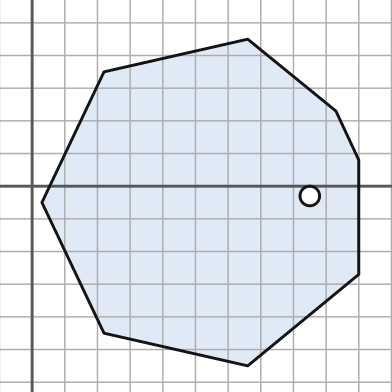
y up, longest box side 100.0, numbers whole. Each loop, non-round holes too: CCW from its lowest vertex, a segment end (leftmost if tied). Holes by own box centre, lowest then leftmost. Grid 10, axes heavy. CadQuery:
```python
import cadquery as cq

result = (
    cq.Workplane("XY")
    .moveTo(66.0, -55.0)
    .lineTo(100.0, -27.0)
    .lineTo(100.0, 8.0)
    .lineTo(93.0, 23.0)
    .lineTo(66.0, 45.0)
    .lineTo(22.0, 35.0)
    .lineTo(3.0, -5.0)
    .lineTo(22.0, -45.0)
    .close()
    .moveTo(85.0, -3.0)
    .circle(3.0)
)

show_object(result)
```